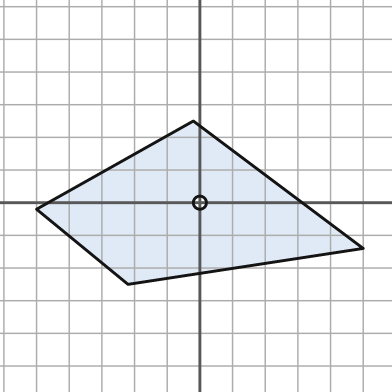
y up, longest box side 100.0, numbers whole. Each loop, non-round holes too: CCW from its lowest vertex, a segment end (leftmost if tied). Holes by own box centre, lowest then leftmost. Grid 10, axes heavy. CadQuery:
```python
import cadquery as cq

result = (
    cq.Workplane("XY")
    .moveTo(-22.0, -25.0)
    .lineTo(50.0, -14.0)
    .lineTo(-2.0, 25.0)
    .lineTo(-50.0, -2.0)
    .close()
    .moveTo(0.0, 0.0)
    .circle(2.0)
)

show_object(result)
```